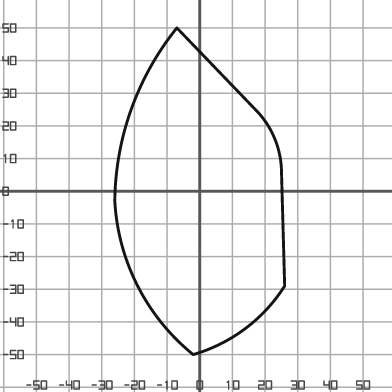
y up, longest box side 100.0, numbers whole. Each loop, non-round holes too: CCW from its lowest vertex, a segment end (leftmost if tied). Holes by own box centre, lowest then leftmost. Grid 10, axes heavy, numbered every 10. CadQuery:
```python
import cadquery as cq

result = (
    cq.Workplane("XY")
    .moveTo(-2.0, -50.0)
    .threePointArc((14.0, -42.0), (26.0, -29.0))
    .lineTo(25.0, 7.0)
    .threePointArc((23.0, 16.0), (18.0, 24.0))
    .lineTo(-7.0, 50.0)
    .threePointArc((-21.0, 25.0), (-26.0, -3.0))
    .threePointArc((-19.0, -29.0), (-2.0, -50.0))
    .close()
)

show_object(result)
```